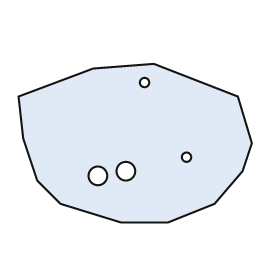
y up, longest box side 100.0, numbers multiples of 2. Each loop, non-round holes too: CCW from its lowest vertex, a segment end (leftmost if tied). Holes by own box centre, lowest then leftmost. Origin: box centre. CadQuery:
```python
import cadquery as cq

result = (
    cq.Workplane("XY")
    .moveTo(-6.0, -34.0)
    .lineTo(14.0, -34.0)
    .lineTo(34.0, -26.0)
    .lineTo(46.0, -12.0)
    .lineTo(50.0, 0.0)
    .lineTo(44.0, 20.0)
    .lineTo(8.0, 34.0)
    .lineTo(-18.0, 32.0)
    .lineTo(-50.0, 20.0)
    .lineTo(-48.0, 2.0)
    .lineTo(-42.0, -16.0)
    .lineTo(-32.0, -26.0)
    .close()
    .moveTo(-16.0, -14.0)
    .circle(4.0)
    .moveTo(-4.0, -12.0)
    .circle(4.0)
    .moveTo(22.0, -6.0)
    .circle(2.0)
    .moveTo(4.0, 26.0)
    .circle(2.0)
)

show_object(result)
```